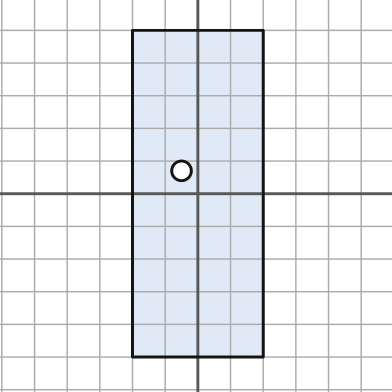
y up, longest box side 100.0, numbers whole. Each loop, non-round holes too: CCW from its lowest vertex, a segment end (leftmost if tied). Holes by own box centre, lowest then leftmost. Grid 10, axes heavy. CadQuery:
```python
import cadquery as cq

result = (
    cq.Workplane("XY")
    .moveTo(-20.0, -50.0)
    .lineTo(20.0, -50.0)
    .lineTo(20.0, 50.0)
    .lineTo(-20.0, 50.0)
    .close()
    .moveTo(-5.0, 7.0)
    .circle(3.0)
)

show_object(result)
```